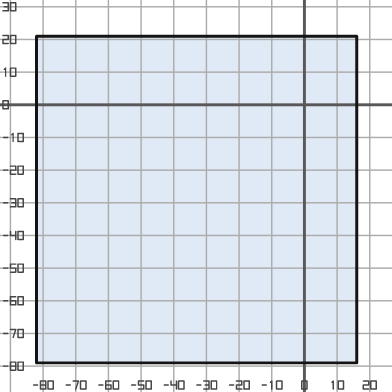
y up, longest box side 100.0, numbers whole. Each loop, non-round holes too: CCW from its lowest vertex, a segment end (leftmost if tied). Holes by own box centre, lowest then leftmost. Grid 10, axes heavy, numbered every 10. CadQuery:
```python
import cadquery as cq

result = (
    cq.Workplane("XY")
    .moveTo(-82.0, -79.0)
    .lineTo(16.0, -79.0)
    .lineTo(16.0, 21.0)
    .lineTo(-82.0, 21.0)
    .close()
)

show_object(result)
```